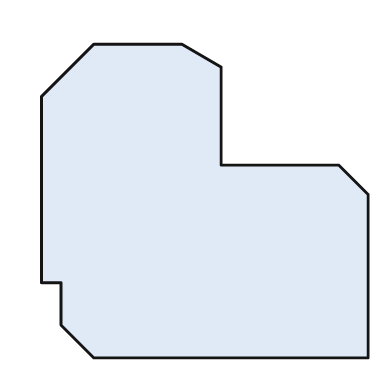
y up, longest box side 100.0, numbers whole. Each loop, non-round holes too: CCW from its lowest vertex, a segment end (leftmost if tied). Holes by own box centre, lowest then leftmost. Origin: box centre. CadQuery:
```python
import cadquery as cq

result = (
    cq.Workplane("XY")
    .moveTo(-34.0, -48.0)
    .lineTo(50.0, -48.0)
    .lineTo(50.0, 2.0)
    .lineTo(41.0, 11.0)
    .lineTo(5.0, 11.0)
    .lineTo(5.0, 41.0)
    .lineTo(-7.0, 48.0)
    .lineTo(-34.0, 48.0)
    .lineTo(-50.0, 32.0)
    .lineTo(-50.0, -25.0)
    .lineTo(-44.0, -25.0)
    .lineTo(-44.0, -38.0)
    .close()
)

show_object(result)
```